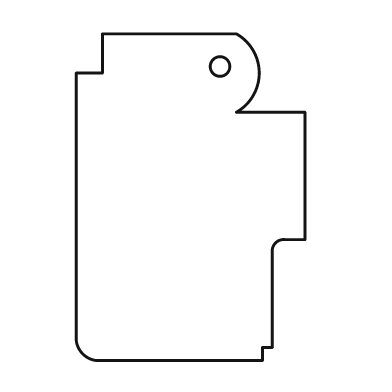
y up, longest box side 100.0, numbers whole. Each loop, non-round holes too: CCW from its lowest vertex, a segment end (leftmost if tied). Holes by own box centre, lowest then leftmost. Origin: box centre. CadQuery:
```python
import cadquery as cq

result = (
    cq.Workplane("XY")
    .moveTo(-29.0, -50.0)
    .lineTo(22.0, -50.0)
    .lineTo(22.0, -46.0)
    .lineTo(25.0, -46.0)
    .lineTo(25.0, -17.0)
    .threePointArc((26.0, -14.0), (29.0, -13.0))
    .lineTo(35.0, -13.0)
    .lineTo(35.0, 26.0)
    .lineTo(14.0, 26.0)
    .threePointArc((21.0, 38.0), (14.0, 50.0))
    .lineTo(-27.0, 50.0)
    .lineTo(-27.0, 38.0)
    .lineTo(-35.0, 38.0)
    .lineTo(-35.0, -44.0)
    .threePointArc((-33.0, -48.0), (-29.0, -50.0))
    .close()
    .moveTo(9.0, 40.0)
    .circle(3.0)
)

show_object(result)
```